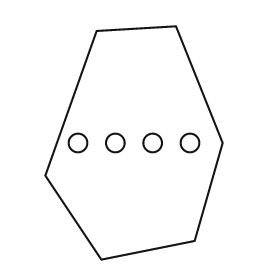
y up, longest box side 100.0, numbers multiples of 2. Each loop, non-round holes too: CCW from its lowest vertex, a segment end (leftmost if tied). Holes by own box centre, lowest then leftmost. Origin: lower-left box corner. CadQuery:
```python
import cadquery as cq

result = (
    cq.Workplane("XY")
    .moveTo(24.0, 0.0)
    .lineTo(64.0, 8.0)
    .lineTo(76.0, 50.0)
    .lineTo(56.0, 100.0)
    .lineTo(22.0, 98.0)
    .lineTo(0.0, 36.0)
    .close()
    .moveTo(14.0, 50.0)
    .circle(4.0)
    .moveTo(30.0, 50.0)
    .circle(4.0)
    .moveTo(46.0, 50.0)
    .circle(4.0)
    .moveTo(62.0, 50.0)
    .circle(4.0)
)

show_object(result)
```